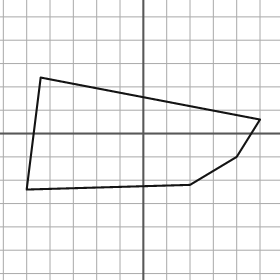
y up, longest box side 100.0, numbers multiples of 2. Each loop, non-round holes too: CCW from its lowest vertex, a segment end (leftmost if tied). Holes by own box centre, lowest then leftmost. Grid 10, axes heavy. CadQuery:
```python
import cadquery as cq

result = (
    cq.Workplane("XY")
    .moveTo(-50.0, -24.0)
    .lineTo(20.0, -22.0)
    .lineTo(40.0, -10.0)
    .lineTo(50.0, 6.0)
    .lineTo(-44.0, 24.0)
    .close()
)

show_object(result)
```